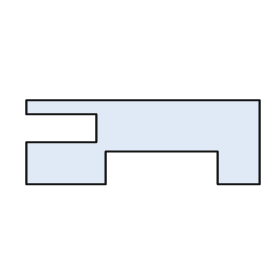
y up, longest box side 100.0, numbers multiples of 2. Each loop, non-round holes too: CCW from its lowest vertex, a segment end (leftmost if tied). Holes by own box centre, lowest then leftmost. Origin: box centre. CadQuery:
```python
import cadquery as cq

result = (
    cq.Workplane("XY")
    .moveTo(-50.0, -18.0)
    .lineTo(-16.0, -18.0)
    .lineTo(-16.0, -4.0)
    .lineTo(32.0, -4.0)
    .lineTo(32.0, -18.0)
    .lineTo(50.0, -18.0)
    .lineTo(50.0, 18.0)
    .lineTo(-50.0, 18.0)
    .lineTo(-50.0, 12.0)
    .lineTo(-20.0, 12.0)
    .lineTo(-20.0, 0.0)
    .lineTo(-50.0, 0.0)
    .close()
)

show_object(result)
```